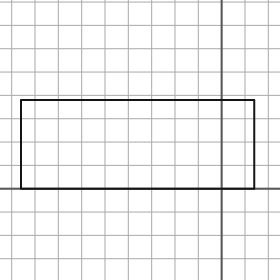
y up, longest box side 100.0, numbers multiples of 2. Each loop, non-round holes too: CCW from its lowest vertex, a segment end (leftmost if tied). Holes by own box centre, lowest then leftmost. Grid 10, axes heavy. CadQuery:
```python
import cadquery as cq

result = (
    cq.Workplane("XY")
    .moveTo(-86.0, 0.0)
    .lineTo(14.0, 0.0)
    .lineTo(14.0, 38.0)
    .lineTo(-86.0, 38.0)
    .close()
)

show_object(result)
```